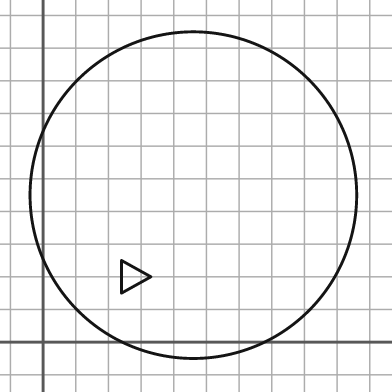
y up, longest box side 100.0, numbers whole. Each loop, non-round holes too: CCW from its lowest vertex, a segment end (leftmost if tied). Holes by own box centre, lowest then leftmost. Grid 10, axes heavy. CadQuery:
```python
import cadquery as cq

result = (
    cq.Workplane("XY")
    .moveTo(46.0, 45.0)
    .circle(50.0)
    .moveTo(24.0, 15.0)
    .lineTo(33.0, 20.0)
    .lineTo(24.0, 25.0)
    .close()
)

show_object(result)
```